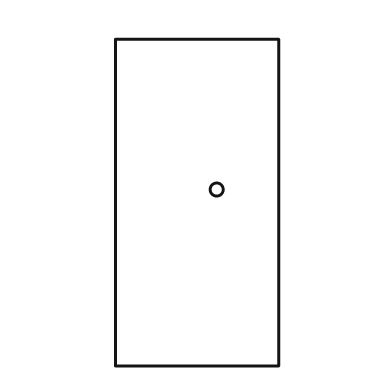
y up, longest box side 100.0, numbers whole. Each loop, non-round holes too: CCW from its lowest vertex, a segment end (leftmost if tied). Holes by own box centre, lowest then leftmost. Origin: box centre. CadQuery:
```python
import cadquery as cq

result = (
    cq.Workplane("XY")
    .moveTo(-25.0, -50.0)
    .lineTo(25.0, -50.0)
    .lineTo(25.0, 50.0)
    .lineTo(-25.0, 50.0)
    .close()
    .moveTo(6.0, 4.0)
    .circle(2.0)
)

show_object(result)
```